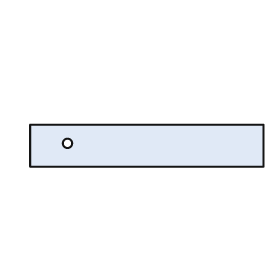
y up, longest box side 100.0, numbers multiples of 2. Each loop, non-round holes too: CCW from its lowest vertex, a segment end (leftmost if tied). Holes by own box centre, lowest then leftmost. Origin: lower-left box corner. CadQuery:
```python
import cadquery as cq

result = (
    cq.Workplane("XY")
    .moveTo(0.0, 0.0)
    .lineTo(100.0, 0.0)
    .lineTo(100.0, 18.0)
    .lineTo(0.0, 18.0)
    .close()
    .moveTo(16.0, 10.0)
    .circle(2.0)
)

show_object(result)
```